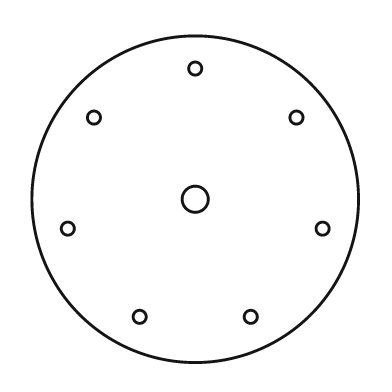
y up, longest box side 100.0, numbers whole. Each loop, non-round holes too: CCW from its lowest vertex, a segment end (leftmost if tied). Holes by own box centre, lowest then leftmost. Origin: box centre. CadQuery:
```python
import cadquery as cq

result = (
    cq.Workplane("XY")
    .moveTo(0.0, 0.0)
    .circle(50.0)
    .moveTo(-17.0, -36.0)
    .circle(2.0)
    .moveTo(17.0, -36.0)
    .circle(2.0)
    .moveTo(-39.0, -9.0)
    .circle(2.0)
    .moveTo(39.0, -9.0)
    .circle(2.0)
    .moveTo(0.0, 0.0)
    .circle(4.0)
    .moveTo(-31.0, 25.0)
    .circle(2.0)
    .moveTo(31.0, 25.0)
    .circle(2.0)
    .moveTo(0.0, 40.0)
    .circle(2.0)
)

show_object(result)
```